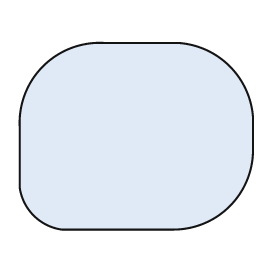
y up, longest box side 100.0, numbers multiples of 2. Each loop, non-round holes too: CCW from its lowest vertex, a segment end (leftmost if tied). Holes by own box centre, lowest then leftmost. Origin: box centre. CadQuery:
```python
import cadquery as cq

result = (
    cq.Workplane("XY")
    .moveTo(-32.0, -40.0)
    .lineTo(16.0, -40.0)
    .threePointArc((40.0, -30.0), (50.0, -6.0))
    .lineTo(50.0, 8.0)
    .threePointArc((40.0, 30.0), (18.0, 40.0))
    .lineTo(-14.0, 40.0)
    .threePointArc((-40.0, 30.0), (-50.0, 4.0))
    .lineTo(-50.0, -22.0)
    .threePointArc((-44.0, -34.0), (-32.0, -40.0))
    .close()
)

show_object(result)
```